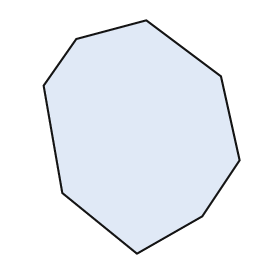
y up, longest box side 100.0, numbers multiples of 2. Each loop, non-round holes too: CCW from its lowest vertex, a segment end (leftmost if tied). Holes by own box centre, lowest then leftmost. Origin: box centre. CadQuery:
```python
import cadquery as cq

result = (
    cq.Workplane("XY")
    .moveTo(-2.0, -50.0)
    .lineTo(26.0, -34.0)
    .lineTo(42.0, -10.0)
    .lineTo(34.0, 26.0)
    .lineTo(2.0, 50.0)
    .lineTo(-28.0, 42.0)
    .lineTo(-42.0, 22.0)
    .lineTo(-34.0, -24.0)
    .close()
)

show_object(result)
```